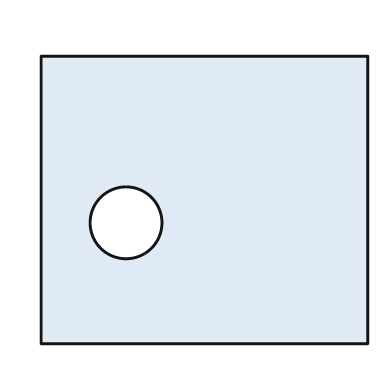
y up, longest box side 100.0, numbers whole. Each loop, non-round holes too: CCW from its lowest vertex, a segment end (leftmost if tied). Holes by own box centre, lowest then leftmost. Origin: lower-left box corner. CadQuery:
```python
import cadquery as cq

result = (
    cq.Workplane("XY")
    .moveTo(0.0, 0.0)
    .lineTo(100.0, 0.0)
    .lineTo(100.0, 88.0)
    .lineTo(0.0, 88.0)
    .close()
    .moveTo(26.0, 37.0)
    .circle(11.0)
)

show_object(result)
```